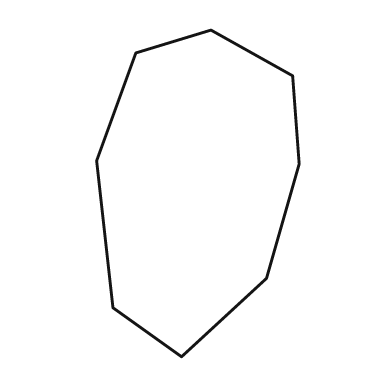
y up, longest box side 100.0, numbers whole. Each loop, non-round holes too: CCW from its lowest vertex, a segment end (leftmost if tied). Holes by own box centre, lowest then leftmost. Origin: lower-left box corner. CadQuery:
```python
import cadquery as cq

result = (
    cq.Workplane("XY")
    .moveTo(26.0, 0.0)
    .lineTo(52.0, 24.0)
    .lineTo(62.0, 59.0)
    .lineTo(60.0, 86.0)
    .lineTo(35.0, 100.0)
    .lineTo(12.0, 93.0)
    .lineTo(0.0, 60.0)
    .lineTo(5.0, 15.0)
    .close()
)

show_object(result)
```